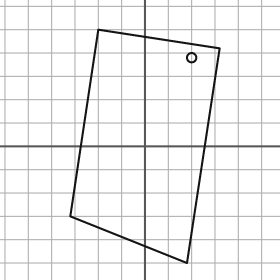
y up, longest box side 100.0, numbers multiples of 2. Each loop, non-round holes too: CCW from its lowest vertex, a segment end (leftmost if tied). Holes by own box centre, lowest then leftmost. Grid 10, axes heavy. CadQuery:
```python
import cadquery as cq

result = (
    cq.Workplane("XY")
    .moveTo(18.0, -50.0)
    .lineTo(32.0, 42.0)
    .lineTo(-20.0, 50.0)
    .lineTo(-32.0, -30.0)
    .close()
    .moveTo(20.0, 38.0)
    .circle(2.0)
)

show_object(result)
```